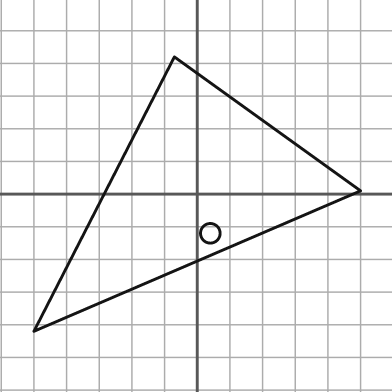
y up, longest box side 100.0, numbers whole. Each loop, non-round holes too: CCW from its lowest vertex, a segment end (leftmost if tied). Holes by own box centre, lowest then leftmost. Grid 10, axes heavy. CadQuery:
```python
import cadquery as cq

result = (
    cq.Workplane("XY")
    .moveTo(-50.0, -42.0)
    .lineTo(50.0, 1.0)
    .lineTo(-7.0, 42.0)
    .close()
    .moveTo(4.0, -12.0)
    .circle(3.0)
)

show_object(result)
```